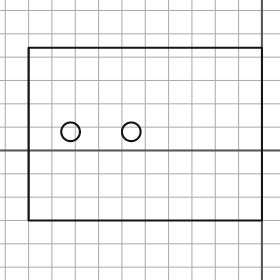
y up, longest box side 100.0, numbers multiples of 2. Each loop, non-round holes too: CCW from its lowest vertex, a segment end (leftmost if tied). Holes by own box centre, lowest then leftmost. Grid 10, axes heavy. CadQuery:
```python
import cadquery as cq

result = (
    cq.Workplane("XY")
    .moveTo(-100.0, -30.0)
    .lineTo(0.0, -30.0)
    .lineTo(0.0, 44.0)
    .lineTo(-100.0, 44.0)
    .close()
    .moveTo(-82.0, 8.0)
    .circle(4.0)
    .moveTo(-56.0, 8.0)
    .circle(4.0)
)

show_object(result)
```